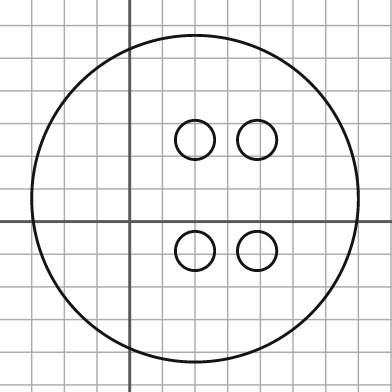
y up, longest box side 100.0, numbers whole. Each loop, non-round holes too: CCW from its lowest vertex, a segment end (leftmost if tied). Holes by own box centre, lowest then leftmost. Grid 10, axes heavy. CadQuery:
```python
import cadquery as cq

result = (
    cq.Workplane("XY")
    .moveTo(20.0, 7.0)
    .circle(50.0)
    .moveTo(20.0, -9.0)
    .circle(6.0)
    .moveTo(39.0, -9.0)
    .circle(6.0)
    .moveTo(20.0, 25.0)
    .circle(6.0)
    .moveTo(39.0, 25.0)
    .circle(6.0)
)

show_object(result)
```